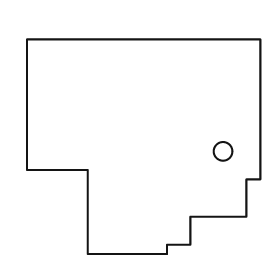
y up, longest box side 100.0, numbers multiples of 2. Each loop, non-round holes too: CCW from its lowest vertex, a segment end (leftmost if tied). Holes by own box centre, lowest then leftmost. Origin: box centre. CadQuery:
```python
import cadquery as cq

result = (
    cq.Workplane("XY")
    .moveTo(-24.0, -46.0)
    .lineTo(10.0, -46.0)
    .lineTo(10.0, -42.0)
    .lineTo(20.0, -42.0)
    .lineTo(20.0, -30.0)
    .lineTo(44.0, -30.0)
    .lineTo(44.0, -14.0)
    .lineTo(50.0, -14.0)
    .lineTo(50.0, 46.0)
    .lineTo(-50.0, 46.0)
    .lineTo(-50.0, -10.0)
    .lineTo(-24.0, -10.0)
    .close()
    .moveTo(34.0, -2.0)
    .circle(4.0)
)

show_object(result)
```